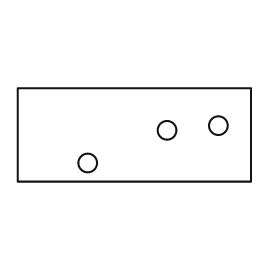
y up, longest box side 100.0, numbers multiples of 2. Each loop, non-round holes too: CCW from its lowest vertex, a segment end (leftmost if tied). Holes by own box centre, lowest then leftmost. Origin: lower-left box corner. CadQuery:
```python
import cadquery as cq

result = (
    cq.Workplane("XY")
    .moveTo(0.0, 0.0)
    .lineTo(100.0, 0.0)
    .lineTo(100.0, 40.0)
    .lineTo(0.0, 40.0)
    .close()
    .moveTo(30.0, 8.0)
    .circle(4.0)
    .moveTo(64.0, 22.0)
    .circle(4.0)
    .moveTo(86.0, 24.0)
    .circle(4.0)
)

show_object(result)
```